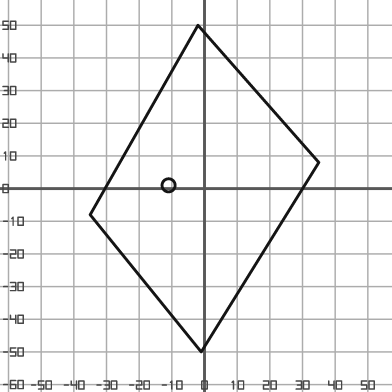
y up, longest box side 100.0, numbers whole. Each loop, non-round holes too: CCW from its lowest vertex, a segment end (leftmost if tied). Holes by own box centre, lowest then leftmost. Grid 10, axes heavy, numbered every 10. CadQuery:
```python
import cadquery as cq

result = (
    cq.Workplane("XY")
    .moveTo(-1.0, -50.0)
    .lineTo(35.0, 8.0)
    .lineTo(-2.0, 50.0)
    .lineTo(-35.0, -8.0)
    .close()
    .moveTo(-11.0, 1.0)
    .circle(2.0)
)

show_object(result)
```